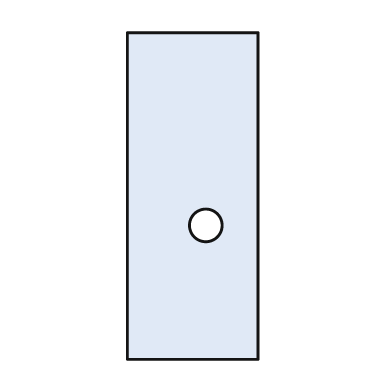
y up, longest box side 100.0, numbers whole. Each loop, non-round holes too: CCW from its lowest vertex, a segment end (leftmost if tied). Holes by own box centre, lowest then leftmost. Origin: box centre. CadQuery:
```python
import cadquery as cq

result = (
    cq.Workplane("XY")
    .moveTo(-20.0, -50.0)
    .lineTo(20.0, -50.0)
    .lineTo(20.0, 50.0)
    .lineTo(-20.0, 50.0)
    .close()
    .moveTo(4.0, -9.0)
    .circle(5.0)
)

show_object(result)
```